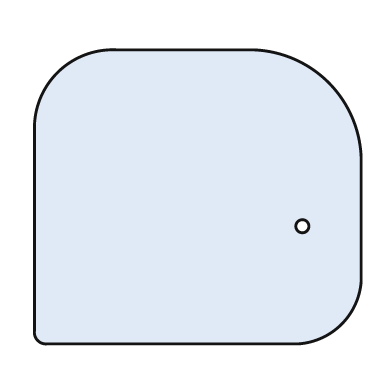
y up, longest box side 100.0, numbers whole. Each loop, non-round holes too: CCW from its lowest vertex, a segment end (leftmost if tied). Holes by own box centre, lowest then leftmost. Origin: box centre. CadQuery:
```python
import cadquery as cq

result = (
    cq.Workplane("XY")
    .moveTo(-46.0, -45.0)
    .lineTo(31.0, -45.0)
    .threePointArc((44.0, -39.0), (50.0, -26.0))
    .lineTo(50.0, 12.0)
    .threePointArc((40.0, 35.0), (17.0, 45.0))
    .lineTo(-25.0, 45.0)
    .threePointArc((-43.0, 38.0), (-50.0, 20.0))
    .lineTo(-50.0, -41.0)
    .threePointArc((-49.0, -44.0), (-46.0, -45.0))
    .close()
    .moveTo(32.0, -9.0)
    .circle(2.0)
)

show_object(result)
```